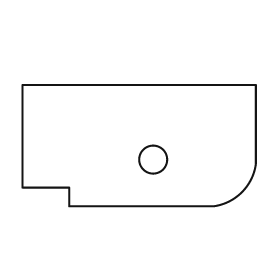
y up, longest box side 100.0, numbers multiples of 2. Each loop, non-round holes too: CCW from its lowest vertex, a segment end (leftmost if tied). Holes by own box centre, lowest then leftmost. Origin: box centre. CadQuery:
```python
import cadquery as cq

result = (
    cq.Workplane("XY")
    .moveTo(-30.0, -26.0)
    .lineTo(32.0, -26.0)
    .threePointArc((44.0, -20.0), (50.0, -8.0))
    .lineTo(50.0, 26.0)
    .lineTo(-50.0, 26.0)
    .lineTo(-50.0, -18.0)
    .lineTo(-30.0, -18.0)
    .close()
    .moveTo(6.0, -6.0)
    .circle(6.0)
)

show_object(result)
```